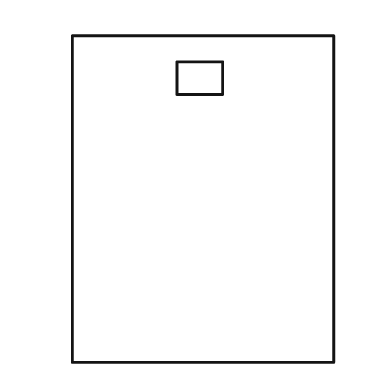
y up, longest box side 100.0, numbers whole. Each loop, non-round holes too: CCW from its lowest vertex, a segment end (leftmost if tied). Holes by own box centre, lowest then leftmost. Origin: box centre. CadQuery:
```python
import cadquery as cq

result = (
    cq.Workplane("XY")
    .moveTo(-40.0, -50.0)
    .lineTo(40.0, -50.0)
    .lineTo(40.0, 50.0)
    .lineTo(-40.0, 50.0)
    .close()
    .moveTo(-8.0, 32.0)
    .lineTo(6.0, 32.0)
    .lineTo(6.0, 42.0)
    .lineTo(-8.0, 42.0)
    .close()
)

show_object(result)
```